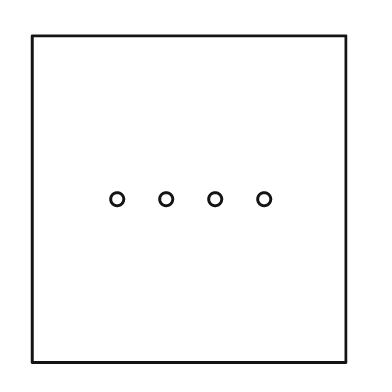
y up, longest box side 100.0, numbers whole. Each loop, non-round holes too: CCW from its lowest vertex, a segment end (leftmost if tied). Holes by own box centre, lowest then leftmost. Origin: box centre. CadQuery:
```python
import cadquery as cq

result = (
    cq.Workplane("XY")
    .moveTo(-48.0, -50.0)
    .lineTo(48.0, -50.0)
    .lineTo(48.0, 50.0)
    .lineTo(-48.0, 50.0)
    .close()
    .moveTo(-22.0, 0.0)
    .circle(2.0)
    .moveTo(-7.0, 0.0)
    .circle(2.0)
    .moveTo(8.0, 0.0)
    .circle(2.0)
    .moveTo(23.0, 0.0)
    .circle(2.0)
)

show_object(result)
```